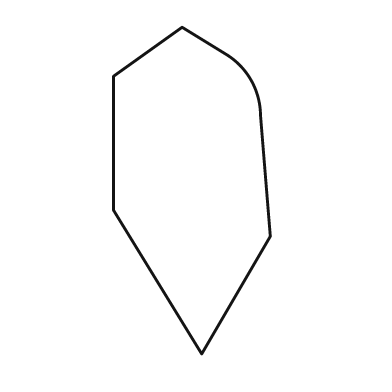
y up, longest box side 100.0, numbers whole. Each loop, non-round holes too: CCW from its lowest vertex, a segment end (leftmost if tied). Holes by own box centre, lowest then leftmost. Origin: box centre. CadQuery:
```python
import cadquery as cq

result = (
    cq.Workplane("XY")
    .moveTo(3.0, -50.0)
    .lineTo(24.0, -14.0)
    .lineTo(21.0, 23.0)
    .threePointArc((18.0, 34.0), (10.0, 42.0))
    .lineTo(-3.0, 50.0)
    .lineTo(-24.0, 35.0)
    .lineTo(-24.0, -6.0)
    .close()
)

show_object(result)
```